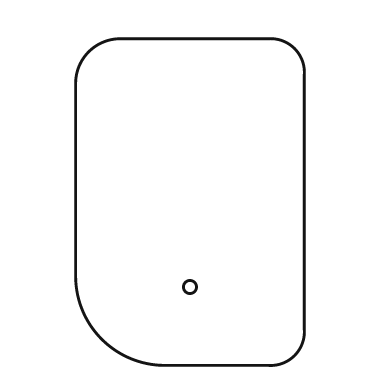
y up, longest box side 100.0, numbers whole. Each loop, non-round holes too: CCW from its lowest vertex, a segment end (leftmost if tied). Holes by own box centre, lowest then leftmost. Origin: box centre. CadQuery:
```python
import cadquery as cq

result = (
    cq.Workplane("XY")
    .moveTo(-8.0, -50.0)
    .lineTo(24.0, -50.0)
    .threePointArc((32.0, -47.0), (35.0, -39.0))
    .lineTo(35.0, 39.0)
    .threePointArc((32.0, 47.0), (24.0, 50.0))
    .lineTo(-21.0, 50.0)
    .threePointArc((-31.0, 46.0), (-35.0, 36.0))
    .lineTo(-35.0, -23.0)
    .threePointArc((-27.0, -42.0), (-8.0, -50.0))
    .close()
    .moveTo(0.0, -26.0)
    .circle(2.0)
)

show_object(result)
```